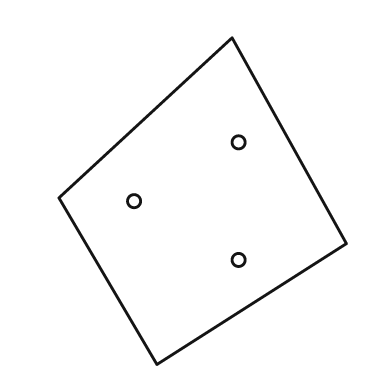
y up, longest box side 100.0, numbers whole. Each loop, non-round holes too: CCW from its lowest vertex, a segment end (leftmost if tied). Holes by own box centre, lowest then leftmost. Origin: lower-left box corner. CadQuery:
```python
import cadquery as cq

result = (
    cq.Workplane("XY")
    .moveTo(30.0, 0.0)
    .lineTo(88.0, 37.0)
    .lineTo(53.0, 100.0)
    .lineTo(0.0, 51.0)
    .close()
    .moveTo(55.0, 32.0)
    .circle(2.0)
    .moveTo(23.0, 50.0)
    .circle(2.0)
    .moveTo(55.0, 68.0)
    .circle(2.0)
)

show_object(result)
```